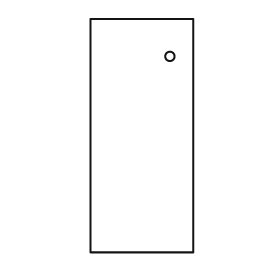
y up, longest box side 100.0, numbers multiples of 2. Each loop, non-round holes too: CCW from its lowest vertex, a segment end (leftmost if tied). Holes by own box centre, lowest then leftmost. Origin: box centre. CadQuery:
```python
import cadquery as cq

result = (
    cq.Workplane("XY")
    .moveTo(-22.0, -50.0)
    .lineTo(22.0, -50.0)
    .lineTo(22.0, 50.0)
    .lineTo(-22.0, 50.0)
    .close()
    .moveTo(12.0, 34.0)
    .circle(2.0)
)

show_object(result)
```